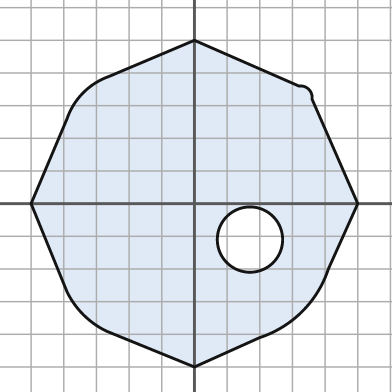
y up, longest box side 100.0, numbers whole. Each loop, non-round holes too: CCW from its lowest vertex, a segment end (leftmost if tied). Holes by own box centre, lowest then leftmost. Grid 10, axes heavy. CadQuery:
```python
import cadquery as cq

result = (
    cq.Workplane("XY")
    .moveTo(0.0, -50.0)
    .lineTo(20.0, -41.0)
    .threePointArc((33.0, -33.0), (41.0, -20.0))
    .lineTo(50.0, 0.0)
    .lineTo(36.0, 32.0)
    .threePointArc((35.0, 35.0), (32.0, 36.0))
    .lineTo(0.0, 50.0)
    .lineTo(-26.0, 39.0)
    .threePointArc((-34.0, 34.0), (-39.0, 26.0))
    .lineTo(-50.0, 0.0)
    .lineTo(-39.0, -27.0)
    .threePointArc((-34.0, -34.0), (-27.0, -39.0))
    .close()
    .moveTo(17.0, -11.0)
    .circle(10.0)
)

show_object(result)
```